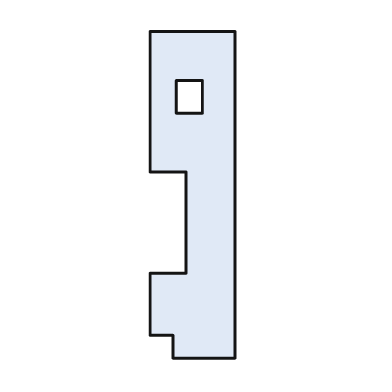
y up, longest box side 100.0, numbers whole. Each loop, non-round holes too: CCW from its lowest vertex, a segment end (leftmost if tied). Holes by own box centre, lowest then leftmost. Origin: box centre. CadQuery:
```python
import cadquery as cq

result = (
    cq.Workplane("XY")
    .moveTo(-6.0, -50.0)
    .lineTo(13.0, -50.0)
    .lineTo(13.0, 50.0)
    .lineTo(-13.0, 50.0)
    .lineTo(-13.0, 7.0)
    .lineTo(-2.0, 7.0)
    .lineTo(-2.0, -24.0)
    .lineTo(-13.0, -24.0)
    .lineTo(-13.0, -43.0)
    .lineTo(-6.0, -43.0)
    .close()
    .moveTo(-5.0, 25.0)
    .lineTo(3.0, 25.0)
    .lineTo(3.0, 35.0)
    .lineTo(-5.0, 35.0)
    .close()
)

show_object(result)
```